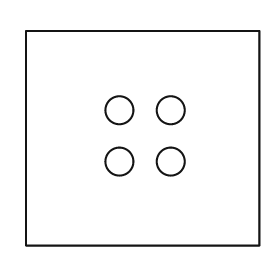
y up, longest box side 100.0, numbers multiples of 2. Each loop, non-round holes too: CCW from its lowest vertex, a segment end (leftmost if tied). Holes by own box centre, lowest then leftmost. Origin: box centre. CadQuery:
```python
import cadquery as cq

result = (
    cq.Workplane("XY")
    .moveTo(-50.0, -46.0)
    .lineTo(50.0, -46.0)
    .lineTo(50.0, 46.0)
    .lineTo(-50.0, 46.0)
    .close()
    .moveTo(-10.0, -10.0)
    .circle(6.0)
    .moveTo(12.0, -10.0)
    .circle(6.0)
    .moveTo(-10.0, 12.0)
    .circle(6.0)
    .moveTo(12.0, 12.0)
    .circle(6.0)
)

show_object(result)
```